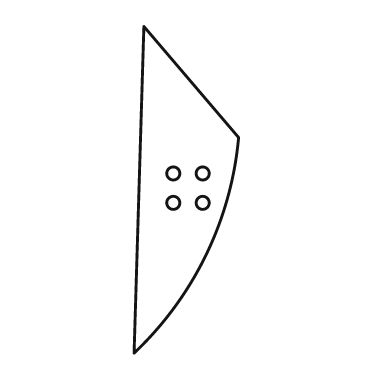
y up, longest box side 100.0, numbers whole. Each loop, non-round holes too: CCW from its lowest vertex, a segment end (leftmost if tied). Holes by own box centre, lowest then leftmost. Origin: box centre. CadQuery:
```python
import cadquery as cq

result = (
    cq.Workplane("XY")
    .moveTo(-16.0, -50.0)
    .threePointArc((6.0, -20.0), (16.0, 16.0))
    .lineTo(-13.0, 50.0)
    .close()
    .moveTo(-4.0, -4.0)
    .circle(2.0)
    .moveTo(5.0, -4.0)
    .circle(2.0)
    .moveTo(-4.0, 5.0)
    .circle(2.0)
    .moveTo(5.0, 5.0)
    .circle(2.0)
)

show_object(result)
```